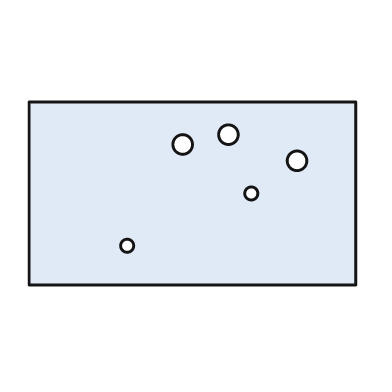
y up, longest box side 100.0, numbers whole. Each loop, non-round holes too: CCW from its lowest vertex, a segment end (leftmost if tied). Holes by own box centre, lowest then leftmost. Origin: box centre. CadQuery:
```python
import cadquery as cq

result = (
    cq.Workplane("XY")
    .moveTo(-50.0, -28.0)
    .lineTo(50.0, -28.0)
    .lineTo(50.0, 28.0)
    .lineTo(-50.0, 28.0)
    .close()
    .moveTo(-20.0, -16.0)
    .circle(2.0)
    .moveTo(18.0, 0.0)
    .circle(2.0)
    .moveTo(32.0, 10.0)
    .circle(3.0)
    .moveTo(-3.0, 15.0)
    .circle(3.0)
    .moveTo(11.0, 18.0)
    .circle(3.0)
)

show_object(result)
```